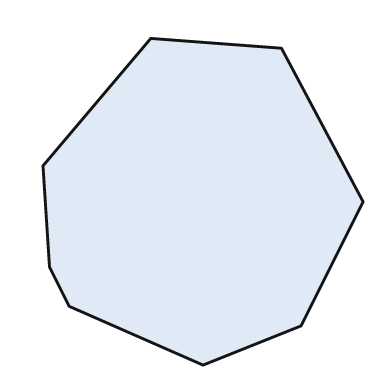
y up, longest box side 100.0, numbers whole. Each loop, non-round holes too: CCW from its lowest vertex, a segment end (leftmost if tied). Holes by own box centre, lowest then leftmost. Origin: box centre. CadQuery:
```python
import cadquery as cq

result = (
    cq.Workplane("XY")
    .moveTo(0.0, -50.0)
    .lineTo(30.0, -38.0)
    .lineTo(49.0, 0.0)
    .lineTo(24.0, 47.0)
    .lineTo(-16.0, 50.0)
    .lineTo(-49.0, 11.0)
    .lineTo(-47.0, -20.0)
    .lineTo(-41.0, -32.0)
    .close()
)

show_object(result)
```